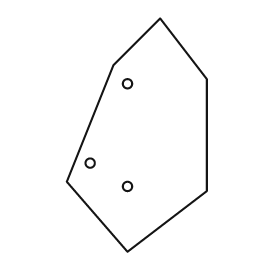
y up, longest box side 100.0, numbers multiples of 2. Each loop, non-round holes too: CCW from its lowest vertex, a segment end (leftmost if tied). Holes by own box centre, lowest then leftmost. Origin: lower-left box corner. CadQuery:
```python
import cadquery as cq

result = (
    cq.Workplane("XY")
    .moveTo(26.0, 0.0)
    .lineTo(60.0, 26.0)
    .lineTo(60.0, 74.0)
    .lineTo(40.0, 100.0)
    .lineTo(20.0, 80.0)
    .lineTo(0.0, 30.0)
    .close()
    .moveTo(26.0, 28.0)
    .circle(2.0)
    .moveTo(10.0, 38.0)
    .circle(2.0)
    .moveTo(26.0, 72.0)
    .circle(2.0)
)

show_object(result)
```